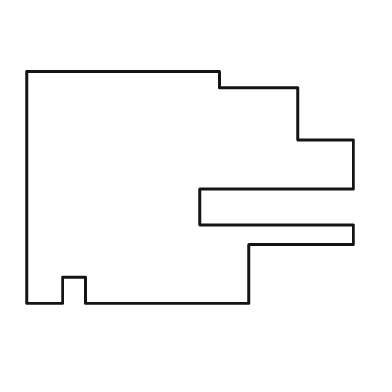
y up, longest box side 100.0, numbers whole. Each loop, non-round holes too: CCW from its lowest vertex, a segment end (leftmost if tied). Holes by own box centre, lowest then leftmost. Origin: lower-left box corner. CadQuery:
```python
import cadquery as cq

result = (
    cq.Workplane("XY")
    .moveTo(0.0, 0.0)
    .lineTo(11.0, 0.0)
    .lineTo(11.0, 8.0)
    .lineTo(18.0, 8.0)
    .lineTo(18.0, 0.0)
    .lineTo(68.0, 0.0)
    .lineTo(68.0, 18.0)
    .lineTo(100.0, 18.0)
    .lineTo(100.0, 24.0)
    .lineTo(53.0, 24.0)
    .lineTo(53.0, 35.0)
    .lineTo(100.0, 35.0)
    .lineTo(100.0, 50.0)
    .lineTo(83.0, 50.0)
    .lineTo(83.0, 66.0)
    .lineTo(59.0, 66.0)
    .lineTo(59.0, 71.0)
    .lineTo(0.0, 71.0)
    .close()
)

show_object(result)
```